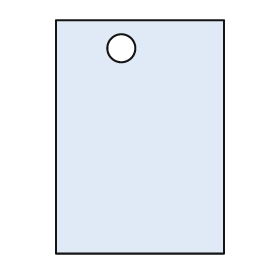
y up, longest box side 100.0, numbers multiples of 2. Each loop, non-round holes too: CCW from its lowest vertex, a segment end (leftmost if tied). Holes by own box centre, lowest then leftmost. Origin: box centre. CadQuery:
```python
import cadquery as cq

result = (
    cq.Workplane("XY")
    .moveTo(-36.0, -50.0)
    .lineTo(36.0, -50.0)
    .lineTo(36.0, 50.0)
    .lineTo(-36.0, 50.0)
    .close()
    .moveTo(-8.0, 38.0)
    .circle(6.0)
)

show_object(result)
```